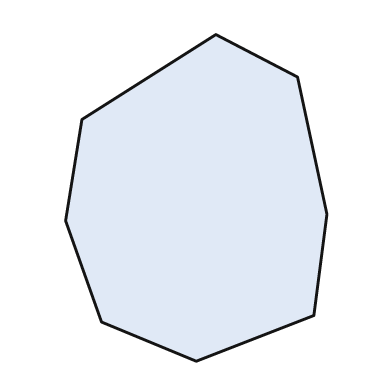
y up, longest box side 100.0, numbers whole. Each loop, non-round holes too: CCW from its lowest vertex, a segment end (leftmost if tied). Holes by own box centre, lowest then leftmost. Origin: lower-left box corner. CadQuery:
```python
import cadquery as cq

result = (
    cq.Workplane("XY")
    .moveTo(40.0, 0.0)
    .lineTo(76.0, 14.0)
    .lineTo(80.0, 45.0)
    .lineTo(71.0, 87.0)
    .lineTo(46.0, 100.0)
    .lineTo(5.0, 74.0)
    .lineTo(0.0, 43.0)
    .lineTo(11.0, 12.0)
    .close()
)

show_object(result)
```